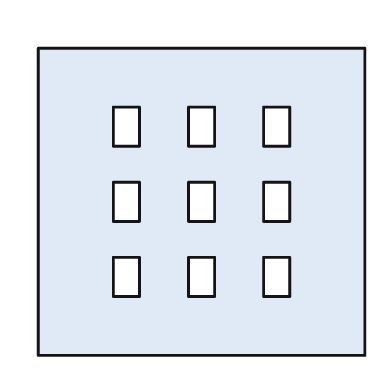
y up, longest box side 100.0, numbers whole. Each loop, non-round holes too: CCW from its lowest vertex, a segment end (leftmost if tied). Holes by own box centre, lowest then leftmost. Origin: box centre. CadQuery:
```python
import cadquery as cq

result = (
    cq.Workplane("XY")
    .moveTo(-50.0, -47.0)
    .lineTo(50.0, -47.0)
    .lineTo(50.0, 47.0)
    .lineTo(-50.0, 47.0)
    .close()
    .moveTo(-27.0, -29.0)
    .lineTo(-19.0, -29.0)
    .lineTo(-19.0, -17.0)
    .lineTo(-27.0, -17.0)
    .close()
    .moveTo(-4.0, -29.0)
    .lineTo(4.0, -29.0)
    .lineTo(4.0, -17.0)
    .lineTo(-4.0, -17.0)
    .close()
    .moveTo(19.0, -29.0)
    .lineTo(27.0, -29.0)
    .lineTo(27.0, -17.0)
    .lineTo(19.0, -17.0)
    .close()
    .moveTo(-27.0, -6.0)
    .lineTo(-19.0, -6.0)
    .lineTo(-19.0, 6.0)
    .lineTo(-27.0, 6.0)
    .close()
    .moveTo(-4.0, -6.0)
    .lineTo(4.0, -6.0)
    .lineTo(4.0, 6.0)
    .lineTo(-4.0, 6.0)
    .close()
    .moveTo(19.0, -6.0)
    .lineTo(27.0, -6.0)
    .lineTo(27.0, 6.0)
    .lineTo(19.0, 6.0)
    .close()
    .moveTo(-27.0, 17.0)
    .lineTo(-19.0, 17.0)
    .lineTo(-19.0, 29.0)
    .lineTo(-27.0, 29.0)
    .close()
    .moveTo(-4.0, 17.0)
    .lineTo(4.0, 17.0)
    .lineTo(4.0, 29.0)
    .lineTo(-4.0, 29.0)
    .close()
    .moveTo(19.0, 17.0)
    .lineTo(27.0, 17.0)
    .lineTo(27.0, 29.0)
    .lineTo(19.0, 29.0)
    .close()
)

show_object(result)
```